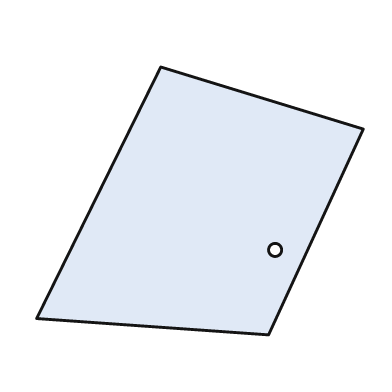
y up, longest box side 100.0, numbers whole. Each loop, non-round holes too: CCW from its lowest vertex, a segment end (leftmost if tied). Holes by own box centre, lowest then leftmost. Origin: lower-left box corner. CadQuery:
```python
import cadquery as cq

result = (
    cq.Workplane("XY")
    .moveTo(71.0, 0.0)
    .lineTo(100.0, 63.0)
    .lineTo(38.0, 82.0)
    .lineTo(0.0, 5.0)
    .close()
    .moveTo(73.0, 26.0)
    .circle(2.0)
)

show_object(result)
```